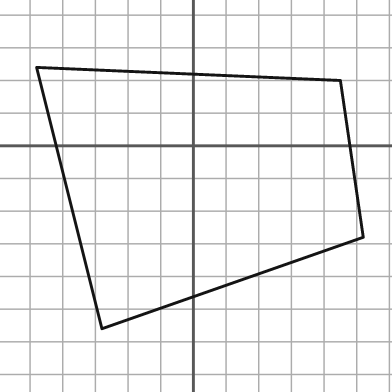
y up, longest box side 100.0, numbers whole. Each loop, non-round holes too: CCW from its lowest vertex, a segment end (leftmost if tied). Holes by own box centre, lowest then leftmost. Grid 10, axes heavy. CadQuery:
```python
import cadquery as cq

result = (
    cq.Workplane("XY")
    .moveTo(-28.0, -56.0)
    .lineTo(52.0, -28.0)
    .lineTo(45.0, 20.0)
    .lineTo(-48.0, 24.0)
    .close()
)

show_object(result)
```